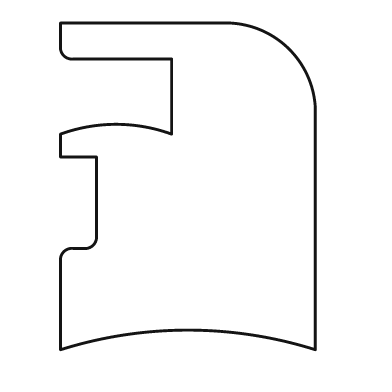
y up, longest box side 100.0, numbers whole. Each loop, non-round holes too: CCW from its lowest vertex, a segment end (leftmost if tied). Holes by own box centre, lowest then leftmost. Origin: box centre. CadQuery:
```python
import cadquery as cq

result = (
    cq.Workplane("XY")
    .moveTo(-39.0, -50.0)
    .threePointArc((0.0, -44.0), (39.0, -50.0))
    .lineTo(39.0, 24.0)
    .threePointArc((31.0, 42.0), (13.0, 50.0))
    .lineTo(-39.0, 50.0)
    .lineTo(-39.0, 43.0)
    .threePointArc((-38.0, 40.0), (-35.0, 39.0))
    .lineTo(-5.0, 39.0)
    .lineTo(-5.0, 16.0)
    .threePointArc((-22.0, 19.0), (-39.0, 16.0))
    .lineTo(-39.0, 9.0)
    .lineTo(-28.0, 9.0)
    .lineTo(-28.0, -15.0)
    .threePointArc((-29.0, -18.0), (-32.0, -19.0))
    .lineTo(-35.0, -19.0)
    .threePointArc((-38.0, -20.0), (-39.0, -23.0))
    .close()
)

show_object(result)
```